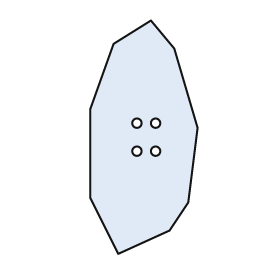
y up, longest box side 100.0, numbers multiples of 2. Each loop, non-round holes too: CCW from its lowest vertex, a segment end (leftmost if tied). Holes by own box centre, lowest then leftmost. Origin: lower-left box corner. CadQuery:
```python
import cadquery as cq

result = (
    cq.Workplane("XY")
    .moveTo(12.0, 0.0)
    .lineTo(34.0, 10.0)
    .lineTo(42.0, 22.0)
    .lineTo(46.0, 54.0)
    .lineTo(36.0, 88.0)
    .lineTo(26.0, 100.0)
    .lineTo(10.0, 90.0)
    .lineTo(0.0, 62.0)
    .lineTo(0.0, 24.0)
    .close()
    .moveTo(20.0, 44.0)
    .circle(2.0)
    .moveTo(28.0, 44.0)
    .circle(2.0)
    .moveTo(20.0, 56.0)
    .circle(2.0)
    .moveTo(28.0, 56.0)
    .circle(2.0)
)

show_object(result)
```